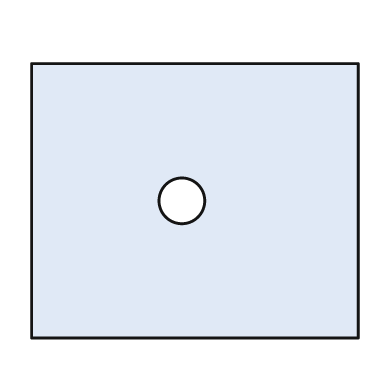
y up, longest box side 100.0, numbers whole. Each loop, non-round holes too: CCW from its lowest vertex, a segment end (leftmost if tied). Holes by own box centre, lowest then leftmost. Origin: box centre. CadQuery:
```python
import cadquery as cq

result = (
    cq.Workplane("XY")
    .moveTo(-50.0, -42.0)
    .lineTo(50.0, -42.0)
    .lineTo(50.0, 42.0)
    .lineTo(-50.0, 42.0)
    .close()
    .moveTo(-4.0, 0.0)
    .circle(7.0)
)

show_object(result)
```